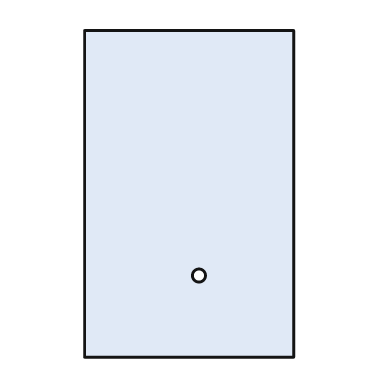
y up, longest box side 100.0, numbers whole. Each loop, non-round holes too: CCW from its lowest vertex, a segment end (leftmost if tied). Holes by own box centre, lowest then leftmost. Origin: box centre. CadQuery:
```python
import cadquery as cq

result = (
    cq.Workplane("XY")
    .moveTo(-32.0, -50.0)
    .lineTo(32.0, -50.0)
    .lineTo(32.0, 50.0)
    .lineTo(-32.0, 50.0)
    .close()
    .moveTo(3.0, -25.0)
    .circle(2.0)
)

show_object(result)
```